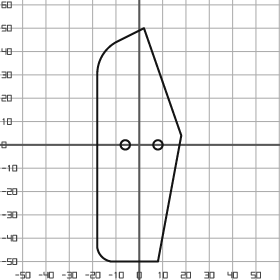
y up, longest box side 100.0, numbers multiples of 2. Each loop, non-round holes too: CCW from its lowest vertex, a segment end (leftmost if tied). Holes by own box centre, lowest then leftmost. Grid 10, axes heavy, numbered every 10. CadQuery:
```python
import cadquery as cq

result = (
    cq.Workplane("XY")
    .moveTo(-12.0, -50.0)
    .lineTo(8.0, -50.0)
    .lineTo(18.0, 4.0)
    .lineTo(2.0, 50.0)
    .lineTo(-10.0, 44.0)
    .threePointArc((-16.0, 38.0), (-18.0, 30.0))
    .lineTo(-18.0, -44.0)
    .threePointArc((-16.0, -48.0), (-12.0, -50.0))
    .close()
    .moveTo(-6.0, 0.0)
    .circle(2.0)
    .moveTo(8.0, 0.0)
    .circle(2.0)
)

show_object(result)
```